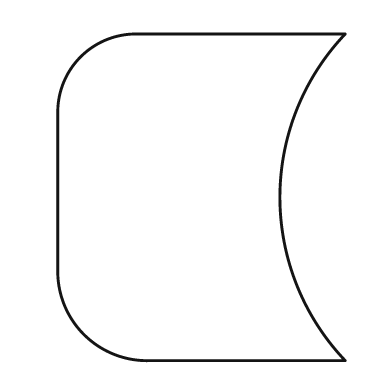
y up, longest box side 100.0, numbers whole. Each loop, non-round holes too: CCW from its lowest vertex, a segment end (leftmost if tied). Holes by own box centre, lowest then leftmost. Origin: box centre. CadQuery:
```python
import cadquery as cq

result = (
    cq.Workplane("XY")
    .moveTo(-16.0, -50.0)
    .lineTo(44.0, -50.0)
    .threePointArc((24.0, 0.0), (44.0, 50.0))
    .lineTo(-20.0, 50.0)
    .threePointArc((-37.0, 43.0), (-44.0, 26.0))
    .lineTo(-44.0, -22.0)
    .threePointArc((-36.0, -42.0), (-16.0, -50.0))
    .close()
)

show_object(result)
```